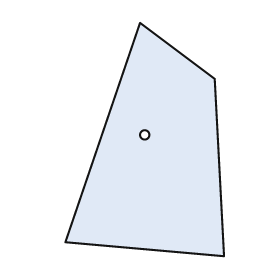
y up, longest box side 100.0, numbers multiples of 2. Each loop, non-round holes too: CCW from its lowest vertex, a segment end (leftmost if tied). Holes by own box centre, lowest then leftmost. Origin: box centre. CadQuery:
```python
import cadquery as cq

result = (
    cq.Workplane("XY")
    .moveTo(34.0, -50.0)
    .lineTo(30.0, 26.0)
    .lineTo(-2.0, 50.0)
    .lineTo(-34.0, -44.0)
    .close()
    .moveTo(0.0, 2.0)
    .circle(2.0)
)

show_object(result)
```